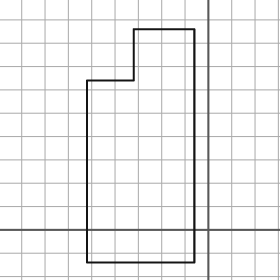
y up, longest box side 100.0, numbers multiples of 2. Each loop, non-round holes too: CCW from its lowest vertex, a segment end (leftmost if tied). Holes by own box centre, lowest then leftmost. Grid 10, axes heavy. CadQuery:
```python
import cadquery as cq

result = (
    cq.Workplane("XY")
    .moveTo(-52.0, -14.0)
    .lineTo(-6.0, -14.0)
    .lineTo(-6.0, 86.0)
    .lineTo(-32.0, 86.0)
    .lineTo(-32.0, 64.0)
    .lineTo(-52.0, 64.0)
    .close()
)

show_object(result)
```